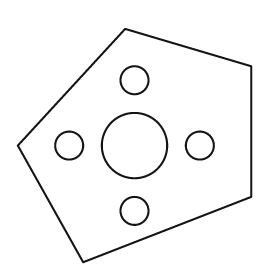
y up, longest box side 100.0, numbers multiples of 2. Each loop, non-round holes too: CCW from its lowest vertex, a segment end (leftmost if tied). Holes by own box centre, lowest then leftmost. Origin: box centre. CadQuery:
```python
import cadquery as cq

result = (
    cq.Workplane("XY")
    .moveTo(-22.0, -50.0)
    .lineTo(50.0, -22.0)
    .lineTo(50.0, 34.0)
    .lineTo(-4.0, 50.0)
    .lineTo(-50.0, 0.0)
    .close()
    .moveTo(0.0, -28.0)
    .circle(6.0)
    .moveTo(-28.0, 0.0)
    .circle(6.0)
    .moveTo(0.0, 0.0)
    .circle(14.0)
    .moveTo(28.0, 0.0)
    .circle(6.0)
    .moveTo(0.0, 28.0)
    .circle(6.0)
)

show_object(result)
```